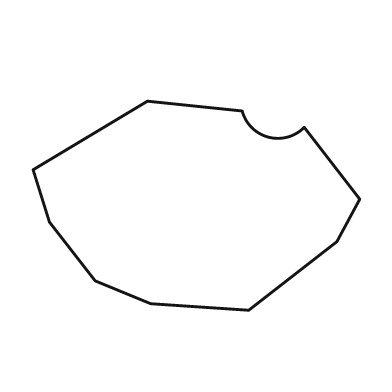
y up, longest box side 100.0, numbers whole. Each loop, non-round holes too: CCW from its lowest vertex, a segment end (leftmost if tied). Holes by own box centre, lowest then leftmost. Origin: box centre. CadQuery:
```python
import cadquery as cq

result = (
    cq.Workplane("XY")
    .moveTo(16.0, -32.0)
    .lineTo(43.0, -11.0)
    .lineTo(50.0, 2.0)
    .lineTo(33.0, 24.0)
    .threePointArc((22.0, 21.0), (14.0, 29.0))
    .lineTo(-15.0, 32.0)
    .lineTo(-50.0, 11.0)
    .lineTo(-45.0, -5.0)
    .lineTo(-31.0, -23.0)
    .lineTo(-14.0, -30.0)
    .close()
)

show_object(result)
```